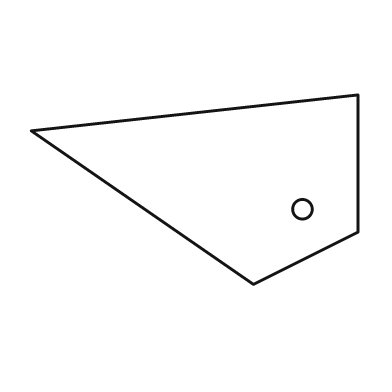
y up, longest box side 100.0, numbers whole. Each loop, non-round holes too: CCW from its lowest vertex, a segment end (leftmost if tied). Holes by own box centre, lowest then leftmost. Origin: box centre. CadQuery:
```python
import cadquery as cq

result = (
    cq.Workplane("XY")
    .moveTo(18.0, -29.0)
    .lineTo(50.0, -13.0)
    .lineTo(50.0, 29.0)
    .lineTo(-50.0, 18.0)
    .close()
    .moveTo(33.0, -6.0)
    .circle(3.0)
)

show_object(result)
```